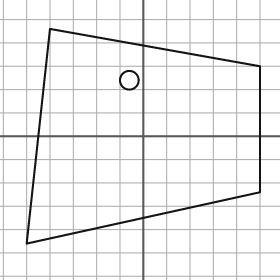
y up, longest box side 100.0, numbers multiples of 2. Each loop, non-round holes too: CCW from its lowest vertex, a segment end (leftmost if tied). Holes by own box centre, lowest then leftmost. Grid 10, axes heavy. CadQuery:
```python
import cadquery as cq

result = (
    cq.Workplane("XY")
    .moveTo(-50.0, -46.0)
    .lineTo(50.0, -24.0)
    .lineTo(50.0, 30.0)
    .lineTo(-40.0, 46.0)
    .close()
    .moveTo(-6.0, 24.0)
    .circle(4.0)
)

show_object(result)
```